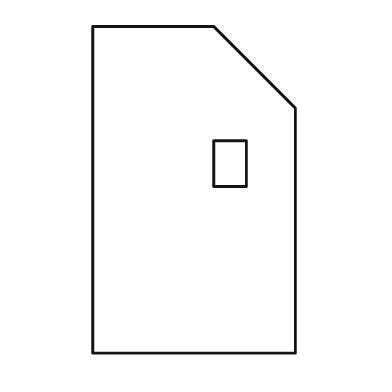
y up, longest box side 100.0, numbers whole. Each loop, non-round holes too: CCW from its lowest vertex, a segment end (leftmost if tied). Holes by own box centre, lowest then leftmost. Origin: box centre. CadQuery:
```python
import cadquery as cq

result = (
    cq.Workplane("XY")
    .moveTo(-31.0, -50.0)
    .lineTo(31.0, -50.0)
    .lineTo(31.0, 25.0)
    .lineTo(6.0, 50.0)
    .lineTo(-31.0, 50.0)
    .close()
    .moveTo(6.0, 1.0)
    .lineTo(16.0, 1.0)
    .lineTo(16.0, 15.0)
    .lineTo(6.0, 15.0)
    .close()
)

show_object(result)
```